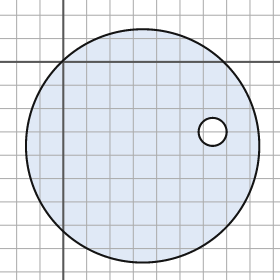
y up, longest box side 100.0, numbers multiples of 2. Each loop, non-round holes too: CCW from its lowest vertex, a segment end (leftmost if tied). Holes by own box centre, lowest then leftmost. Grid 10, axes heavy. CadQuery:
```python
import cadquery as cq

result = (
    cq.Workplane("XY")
    .moveTo(34.0, -36.0)
    .circle(50.0)
    .moveTo(64.0, -30.0)
    .circle(6.0)
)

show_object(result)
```